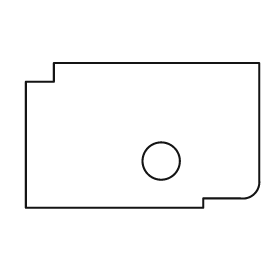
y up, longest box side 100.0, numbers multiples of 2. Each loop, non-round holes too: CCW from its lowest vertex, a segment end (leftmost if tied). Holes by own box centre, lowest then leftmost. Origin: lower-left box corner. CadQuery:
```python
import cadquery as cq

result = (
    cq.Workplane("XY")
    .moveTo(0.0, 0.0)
    .lineTo(76.0, 0.0)
    .lineTo(76.0, 4.0)
    .lineTo(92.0, 4.0)
    .threePointArc((98.0, 6.0), (100.0, 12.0))
    .lineTo(100.0, 62.0)
    .lineTo(12.0, 62.0)
    .lineTo(12.0, 54.0)
    .lineTo(0.0, 54.0)
    .close()
    .moveTo(58.0, 20.0)
    .circle(8.0)
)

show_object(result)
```